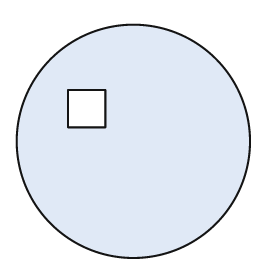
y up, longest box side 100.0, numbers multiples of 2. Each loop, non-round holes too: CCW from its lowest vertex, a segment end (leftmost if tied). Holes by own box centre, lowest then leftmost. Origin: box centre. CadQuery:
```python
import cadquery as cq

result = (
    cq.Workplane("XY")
    .moveTo(0.0, 0.0)
    .circle(50.0)
    .moveTo(-28.0, 6.0)
    .lineTo(-12.0, 6.0)
    .lineTo(-12.0, 22.0)
    .lineTo(-28.0, 22.0)
    .close()
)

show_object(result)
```